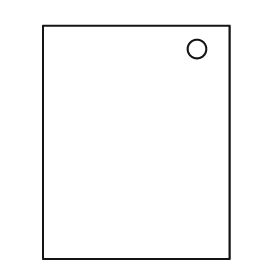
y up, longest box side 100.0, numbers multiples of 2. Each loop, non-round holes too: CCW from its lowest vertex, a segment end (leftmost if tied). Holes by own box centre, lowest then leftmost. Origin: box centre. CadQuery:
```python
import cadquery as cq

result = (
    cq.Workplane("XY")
    .moveTo(-40.0, -50.0)
    .lineTo(40.0, -50.0)
    .lineTo(40.0, 50.0)
    .lineTo(-40.0, 50.0)
    .close()
    .moveTo(26.0, 40.0)
    .circle(4.0)
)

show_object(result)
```